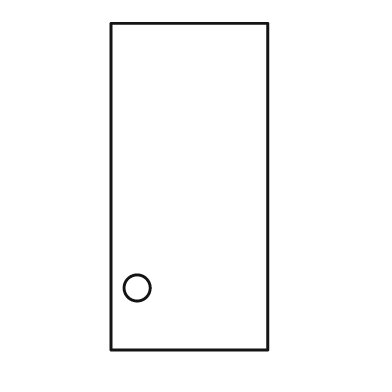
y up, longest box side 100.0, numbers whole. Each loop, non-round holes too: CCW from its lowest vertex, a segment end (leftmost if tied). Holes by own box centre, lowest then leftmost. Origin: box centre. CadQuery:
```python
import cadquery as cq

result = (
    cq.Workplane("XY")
    .moveTo(-24.0, -50.0)
    .lineTo(24.0, -50.0)
    .lineTo(24.0, 50.0)
    .lineTo(-24.0, 50.0)
    .close()
    .moveTo(-16.0, -31.0)
    .circle(4.0)
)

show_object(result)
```